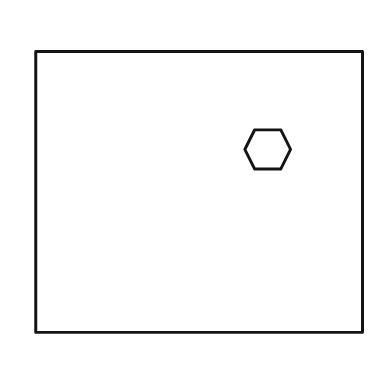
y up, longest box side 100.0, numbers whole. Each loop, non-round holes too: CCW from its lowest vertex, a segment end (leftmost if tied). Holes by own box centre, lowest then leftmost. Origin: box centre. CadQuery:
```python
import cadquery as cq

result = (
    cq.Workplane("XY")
    .moveTo(-50.0, -43.0)
    .lineTo(50.0, -43.0)
    .lineTo(50.0, 43.0)
    .lineTo(-50.0, 43.0)
    .close()
    .moveTo(17.0, 7.0)
    .lineTo(25.0, 7.0)
    .lineTo(28.0, 13.0)
    .lineTo(25.0, 19.0)
    .lineTo(17.0, 19.0)
    .lineTo(14.0, 13.0)
    .close()
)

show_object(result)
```